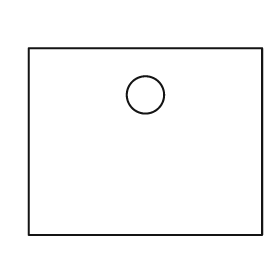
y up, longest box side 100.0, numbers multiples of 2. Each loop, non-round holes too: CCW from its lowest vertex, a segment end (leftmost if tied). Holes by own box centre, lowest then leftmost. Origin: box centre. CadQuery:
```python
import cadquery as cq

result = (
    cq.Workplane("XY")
    .moveTo(-50.0, -40.0)
    .lineTo(50.0, -40.0)
    .lineTo(50.0, 40.0)
    .lineTo(-50.0, 40.0)
    .close()
    .moveTo(0.0, 20.0)
    .circle(8.0)
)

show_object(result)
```